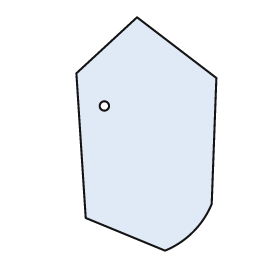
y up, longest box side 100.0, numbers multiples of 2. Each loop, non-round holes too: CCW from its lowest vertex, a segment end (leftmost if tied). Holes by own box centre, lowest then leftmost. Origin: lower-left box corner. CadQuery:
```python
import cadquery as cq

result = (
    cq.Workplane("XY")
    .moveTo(38.0, 0.0)
    .threePointArc((50.0, 8.0), (58.0, 20.0))
    .lineTo(60.0, 74.0)
    .lineTo(26.0, 100.0)
    .lineTo(0.0, 76.0)
    .lineTo(4.0, 14.0)
    .close()
    .moveTo(12.0, 62.0)
    .circle(2.0)
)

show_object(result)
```